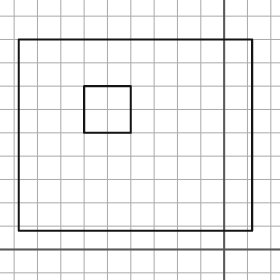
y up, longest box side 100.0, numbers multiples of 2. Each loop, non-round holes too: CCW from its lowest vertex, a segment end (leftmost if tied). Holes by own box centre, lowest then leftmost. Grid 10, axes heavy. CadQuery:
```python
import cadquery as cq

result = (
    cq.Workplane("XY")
    .moveTo(-88.0, 8.0)
    .lineTo(12.0, 8.0)
    .lineTo(12.0, 90.0)
    .lineTo(-88.0, 90.0)
    .close()
    .moveTo(-60.0, 50.0)
    .lineTo(-40.0, 50.0)
    .lineTo(-40.0, 70.0)
    .lineTo(-60.0, 70.0)
    .close()
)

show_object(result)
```